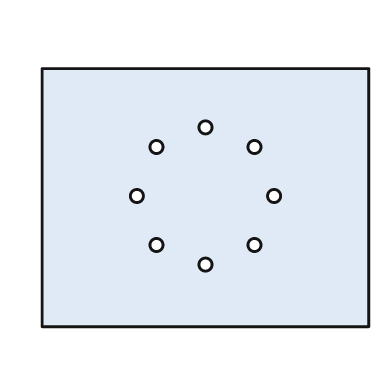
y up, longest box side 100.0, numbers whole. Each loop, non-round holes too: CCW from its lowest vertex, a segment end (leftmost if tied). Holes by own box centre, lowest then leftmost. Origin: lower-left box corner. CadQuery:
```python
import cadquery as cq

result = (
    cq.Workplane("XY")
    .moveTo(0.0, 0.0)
    .lineTo(100.0, 0.0)
    .lineTo(100.0, 79.0)
    .lineTo(0.0, 79.0)
    .close()
    .moveTo(50.0, 19.0)
    .circle(2.0)
    .moveTo(35.0, 25.0)
    .circle(2.0)
    .moveTo(65.0, 25.0)
    .circle(2.0)
    .moveTo(29.0, 40.0)
    .circle(2.0)
    .moveTo(71.0, 40.0)
    .circle(2.0)
    .moveTo(35.0, 55.0)
    .circle(2.0)
    .moveTo(65.0, 55.0)
    .circle(2.0)
    .moveTo(50.0, 61.0)
    .circle(2.0)
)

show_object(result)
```